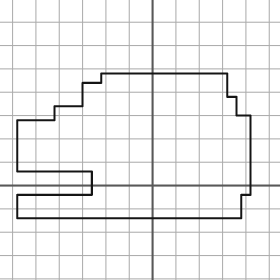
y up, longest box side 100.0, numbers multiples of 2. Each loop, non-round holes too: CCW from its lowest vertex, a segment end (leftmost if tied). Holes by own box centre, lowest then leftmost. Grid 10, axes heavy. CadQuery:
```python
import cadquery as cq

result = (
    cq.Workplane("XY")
    .moveTo(-58.0, -14.0)
    .lineTo(38.0, -14.0)
    .lineTo(38.0, -4.0)
    .lineTo(42.0, -4.0)
    .lineTo(42.0, 30.0)
    .lineTo(36.0, 30.0)
    .lineTo(36.0, 38.0)
    .lineTo(32.0, 38.0)
    .lineTo(32.0, 48.0)
    .lineTo(-22.0, 48.0)
    .lineTo(-22.0, 44.0)
    .lineTo(-30.0, 44.0)
    .lineTo(-30.0, 34.0)
    .lineTo(-42.0, 34.0)
    .lineTo(-42.0, 28.0)
    .lineTo(-58.0, 28.0)
    .lineTo(-58.0, 6.0)
    .lineTo(-26.0, 6.0)
    .lineTo(-26.0, -4.0)
    .lineTo(-58.0, -4.0)
    .close()
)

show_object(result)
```